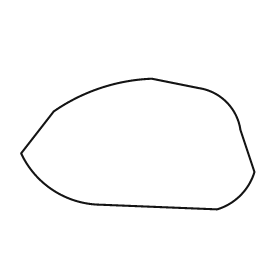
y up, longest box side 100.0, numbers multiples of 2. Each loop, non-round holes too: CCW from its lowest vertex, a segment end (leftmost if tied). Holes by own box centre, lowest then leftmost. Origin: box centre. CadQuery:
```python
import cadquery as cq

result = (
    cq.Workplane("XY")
    .moveTo(34.0, -28.0)
    .threePointArc((44.0, -22.0), (50.0, -12.0))
    .lineTo(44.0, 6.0)
    .threePointArc((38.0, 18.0), (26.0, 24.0))
    .lineTo(6.0, 28.0)
    .threePointArc((-16.0, 24.0), (-36.0, 14.0))
    .lineTo(-50.0, -4.0)
    .threePointArc((-36.0, -20.0), (-16.0, -26.0))
    .close()
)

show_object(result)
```